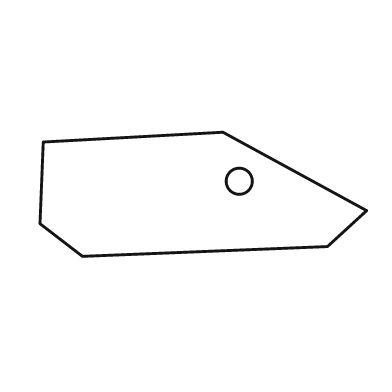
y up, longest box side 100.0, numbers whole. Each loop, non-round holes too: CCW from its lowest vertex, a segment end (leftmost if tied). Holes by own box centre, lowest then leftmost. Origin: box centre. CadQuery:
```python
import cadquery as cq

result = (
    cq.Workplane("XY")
    .moveTo(-37.0, -19.0)
    .lineTo(38.0, -16.0)
    .lineTo(50.0, -5.0)
    .lineTo(6.0, 19.0)
    .lineTo(-49.0, 16.0)
    .lineTo(-50.0, -9.0)
    .close()
    .moveTo(11.0, 4.0)
    .circle(4.0)
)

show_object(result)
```